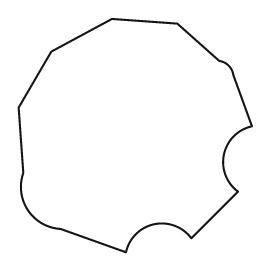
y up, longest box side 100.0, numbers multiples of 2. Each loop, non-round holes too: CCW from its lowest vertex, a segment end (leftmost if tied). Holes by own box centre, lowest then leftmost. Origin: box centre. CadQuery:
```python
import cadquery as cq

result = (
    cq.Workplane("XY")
    .moveTo(-4.0, -50.0)
    .threePointArc((8.0, -38.0), (24.0, -44.0))
    .lineTo(44.0, -24.0)
    .threePointArc((38.0, -8.0), (50.0, 4.0))
    .lineTo(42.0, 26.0)
    .threePointArc((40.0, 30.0), (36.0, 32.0))
    .lineTo(18.0, 48.0)
    .lineTo(-10.0, 50.0)
    .lineTo(-36.0, 36.0)
    .lineTo(-50.0, 12.0)
    .lineTo(-48.0, -16.0)
    .threePointArc((-46.0, -32.0), (-32.0, -40.0))
    .close()
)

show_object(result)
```